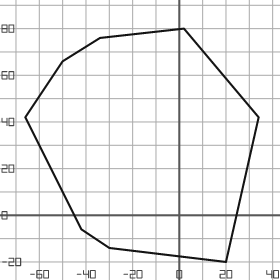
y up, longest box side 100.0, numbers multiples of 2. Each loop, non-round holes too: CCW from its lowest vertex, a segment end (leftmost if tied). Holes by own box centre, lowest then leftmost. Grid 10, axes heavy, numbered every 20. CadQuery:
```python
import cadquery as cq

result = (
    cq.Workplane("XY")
    .moveTo(20.0, -20.0)
    .lineTo(34.0, 42.0)
    .lineTo(2.0, 80.0)
    .lineTo(-34.0, 76.0)
    .lineTo(-50.0, 66.0)
    .lineTo(-66.0, 42.0)
    .lineTo(-42.0, -6.0)
    .lineTo(-30.0, -14.0)
    .close()
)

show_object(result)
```